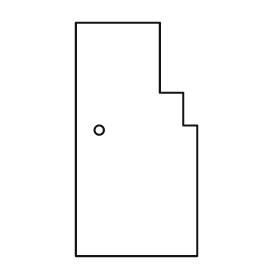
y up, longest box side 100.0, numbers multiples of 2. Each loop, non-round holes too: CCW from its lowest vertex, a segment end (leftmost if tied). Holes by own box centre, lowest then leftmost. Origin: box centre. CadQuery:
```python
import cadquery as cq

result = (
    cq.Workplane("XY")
    .moveTo(-26.0, -50.0)
    .lineTo(26.0, -50.0)
    .lineTo(26.0, 6.0)
    .lineTo(20.0, 6.0)
    .lineTo(20.0, 20.0)
    .lineTo(10.0, 20.0)
    .lineTo(10.0, 50.0)
    .lineTo(-26.0, 50.0)
    .close()
    .moveTo(-16.0, 4.0)
    .circle(2.0)
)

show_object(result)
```